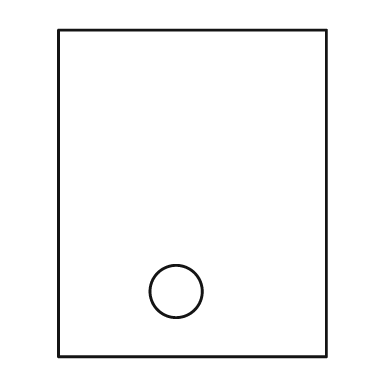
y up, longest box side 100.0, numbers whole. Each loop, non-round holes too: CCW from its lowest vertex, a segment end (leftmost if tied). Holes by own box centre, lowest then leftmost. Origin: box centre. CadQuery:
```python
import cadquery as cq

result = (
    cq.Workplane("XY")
    .moveTo(-41.0, -50.0)
    .lineTo(41.0, -50.0)
    .lineTo(41.0, 50.0)
    .lineTo(-41.0, 50.0)
    .close()
    .moveTo(-5.0, -30.0)
    .circle(8.0)
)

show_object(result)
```